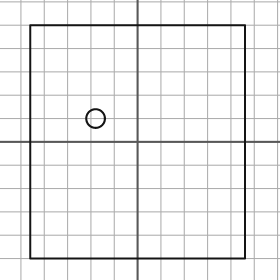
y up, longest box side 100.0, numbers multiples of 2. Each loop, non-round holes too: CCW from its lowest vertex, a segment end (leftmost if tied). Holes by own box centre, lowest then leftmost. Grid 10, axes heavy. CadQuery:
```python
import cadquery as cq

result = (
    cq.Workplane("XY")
    .moveTo(-46.0, -50.0)
    .lineTo(46.0, -50.0)
    .lineTo(46.0, 50.0)
    .lineTo(-46.0, 50.0)
    .close()
    .moveTo(-18.0, 10.0)
    .circle(4.0)
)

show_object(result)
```